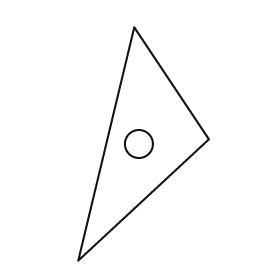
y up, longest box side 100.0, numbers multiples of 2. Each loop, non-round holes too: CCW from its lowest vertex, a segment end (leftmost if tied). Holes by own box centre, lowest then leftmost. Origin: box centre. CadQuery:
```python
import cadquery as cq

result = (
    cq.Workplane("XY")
    .moveTo(-28.0, -50.0)
    .lineTo(28.0, 2.0)
    .lineTo(-4.0, 50.0)
    .close()
    .moveTo(-2.0, 0.0)
    .circle(6.0)
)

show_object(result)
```